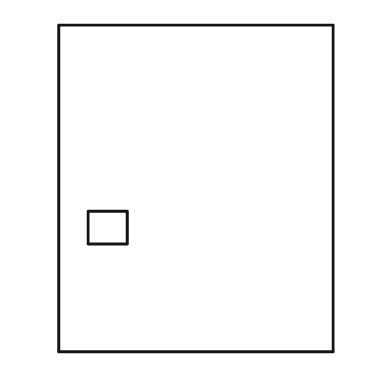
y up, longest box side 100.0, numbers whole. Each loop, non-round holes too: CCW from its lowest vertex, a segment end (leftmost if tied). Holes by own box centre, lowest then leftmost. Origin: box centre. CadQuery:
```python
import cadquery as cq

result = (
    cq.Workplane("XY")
    .moveTo(-42.0, -50.0)
    .lineTo(42.0, -50.0)
    .lineTo(42.0, 50.0)
    .lineTo(-42.0, 50.0)
    .close()
    .moveTo(-33.0, -17.0)
    .lineTo(-21.0, -17.0)
    .lineTo(-21.0, -7.0)
    .lineTo(-33.0, -7.0)
    .close()
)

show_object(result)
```